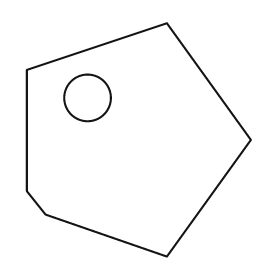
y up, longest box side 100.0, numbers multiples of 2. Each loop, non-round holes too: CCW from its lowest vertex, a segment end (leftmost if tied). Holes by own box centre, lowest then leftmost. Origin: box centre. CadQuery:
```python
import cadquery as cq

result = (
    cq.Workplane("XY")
    .moveTo(12.0, -50.0)
    .lineTo(48.0, 0.0)
    .lineTo(12.0, 50.0)
    .lineTo(-48.0, 30.0)
    .lineTo(-48.0, -22.0)
    .lineTo(-40.0, -32.0)
    .close()
    .moveTo(-22.0, 18.0)
    .circle(10.0)
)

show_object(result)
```